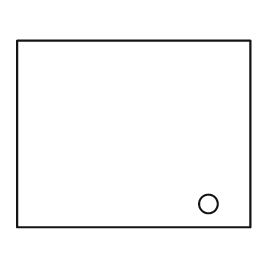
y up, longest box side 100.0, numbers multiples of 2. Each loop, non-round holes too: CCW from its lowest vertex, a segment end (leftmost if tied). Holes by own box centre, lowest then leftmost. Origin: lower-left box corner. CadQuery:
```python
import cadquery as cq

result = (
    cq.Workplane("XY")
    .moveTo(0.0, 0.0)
    .lineTo(100.0, 0.0)
    .lineTo(100.0, 80.0)
    .lineTo(0.0, 80.0)
    .close()
    .moveTo(82.0, 10.0)
    .circle(4.0)
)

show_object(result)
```